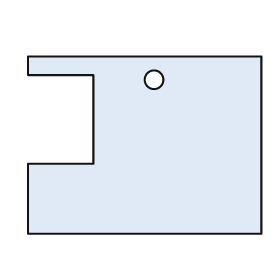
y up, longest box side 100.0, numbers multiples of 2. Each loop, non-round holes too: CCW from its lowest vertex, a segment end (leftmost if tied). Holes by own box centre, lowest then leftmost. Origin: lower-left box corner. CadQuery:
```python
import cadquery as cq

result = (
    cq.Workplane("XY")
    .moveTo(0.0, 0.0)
    .lineTo(100.0, 0.0)
    .lineTo(100.0, 76.0)
    .lineTo(0.0, 76.0)
    .lineTo(0.0, 68.0)
    .lineTo(28.0, 68.0)
    .lineTo(28.0, 30.0)
    .lineTo(0.0, 30.0)
    .close()
    .moveTo(54.0, 66.0)
    .circle(4.0)
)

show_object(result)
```